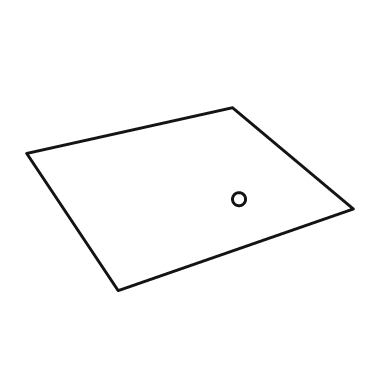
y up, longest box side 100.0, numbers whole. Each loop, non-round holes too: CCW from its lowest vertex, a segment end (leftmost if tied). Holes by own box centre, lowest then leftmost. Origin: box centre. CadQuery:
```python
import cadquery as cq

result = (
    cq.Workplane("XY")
    .moveTo(-22.0, -28.0)
    .lineTo(50.0, -3.0)
    .lineTo(13.0, 28.0)
    .lineTo(-50.0, 14.0)
    .close()
    .moveTo(15.0, 0.0)
    .circle(2.0)
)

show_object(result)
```